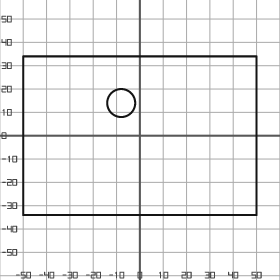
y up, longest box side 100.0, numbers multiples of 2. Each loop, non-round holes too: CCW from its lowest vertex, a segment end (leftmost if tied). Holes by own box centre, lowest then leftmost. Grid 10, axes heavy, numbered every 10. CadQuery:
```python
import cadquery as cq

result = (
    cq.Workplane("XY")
    .moveTo(-50.0, -34.0)
    .lineTo(50.0, -34.0)
    .lineTo(50.0, 34.0)
    .lineTo(-50.0, 34.0)
    .close()
    .moveTo(-8.0, 14.0)
    .circle(6.0)
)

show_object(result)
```